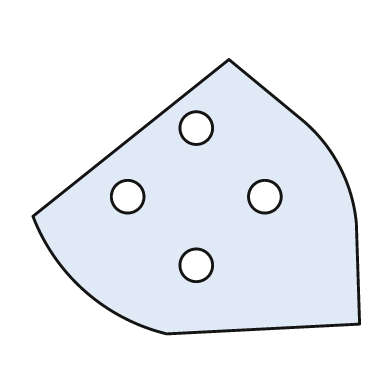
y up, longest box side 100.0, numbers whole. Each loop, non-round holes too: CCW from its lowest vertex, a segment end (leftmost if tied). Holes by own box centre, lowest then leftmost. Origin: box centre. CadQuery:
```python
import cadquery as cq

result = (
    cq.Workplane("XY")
    .moveTo(-9.0, -42.0)
    .lineTo(50.0, -39.0)
    .lineTo(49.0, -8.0)
    .threePointArc((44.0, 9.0), (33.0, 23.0))
    .lineTo(10.0, 42.0)
    .lineTo(-50.0, -6.0)
    .threePointArc((-34.0, -29.0), (-9.0, -42.0))
    .close()
    .moveTo(0.0, -21.0)
    .circle(5.0)
    .moveTo(-21.0, 0.0)
    .circle(5.0)
    .moveTo(21.0, 0.0)
    .circle(5.0)
    .moveTo(0.0, 21.0)
    .circle(5.0)
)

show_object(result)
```